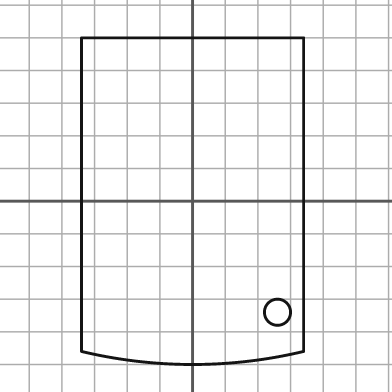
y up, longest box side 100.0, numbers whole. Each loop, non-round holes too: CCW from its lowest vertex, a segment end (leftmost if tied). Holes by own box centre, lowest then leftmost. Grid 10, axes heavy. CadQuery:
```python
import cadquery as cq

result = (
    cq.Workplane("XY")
    .moveTo(-34.0, -46.0)
    .threePointArc((0.0, -50.0), (34.0, -46.0))
    .lineTo(34.0, 50.0)
    .lineTo(-34.0, 50.0)
    .close()
    .moveTo(26.0, -34.0)
    .circle(4.0)
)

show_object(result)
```